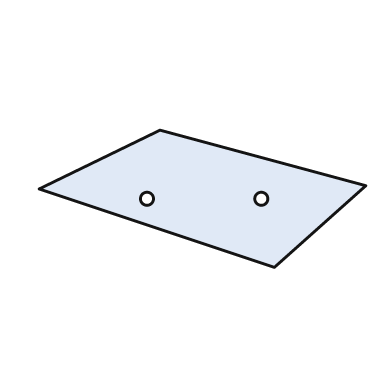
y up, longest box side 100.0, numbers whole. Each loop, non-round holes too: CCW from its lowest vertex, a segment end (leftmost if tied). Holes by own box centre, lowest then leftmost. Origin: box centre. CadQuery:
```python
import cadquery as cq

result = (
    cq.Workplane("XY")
    .moveTo(22.0, -21.0)
    .lineTo(50.0, 4.0)
    .lineTo(-13.0, 21.0)
    .lineTo(-50.0, 3.0)
    .close()
    .moveTo(-17.0, 0.0)
    .circle(2.0)
    .moveTo(18.0, 0.0)
    .circle(2.0)
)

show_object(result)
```